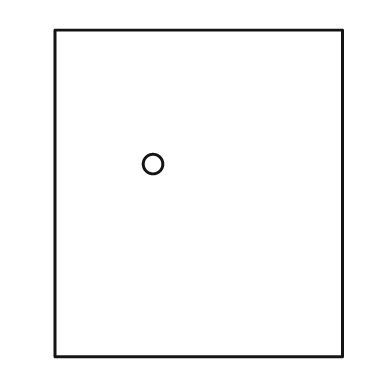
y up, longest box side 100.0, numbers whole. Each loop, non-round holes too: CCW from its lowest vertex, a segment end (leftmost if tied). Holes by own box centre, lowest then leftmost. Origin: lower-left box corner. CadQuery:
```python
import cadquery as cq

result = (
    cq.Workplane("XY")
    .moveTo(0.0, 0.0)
    .lineTo(88.0, 0.0)
    .lineTo(88.0, 100.0)
    .lineTo(0.0, 100.0)
    .close()
    .moveTo(30.0, 59.0)
    .circle(3.0)
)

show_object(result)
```